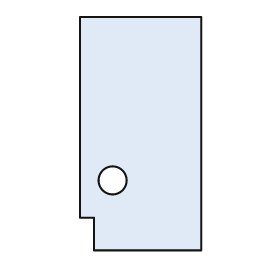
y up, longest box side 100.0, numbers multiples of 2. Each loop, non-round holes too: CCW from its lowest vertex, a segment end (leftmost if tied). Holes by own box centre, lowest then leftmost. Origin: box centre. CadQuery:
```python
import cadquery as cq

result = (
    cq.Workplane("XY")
    .moveTo(-20.0, -50.0)
    .lineTo(26.0, -50.0)
    .lineTo(26.0, 50.0)
    .lineTo(-26.0, 50.0)
    .lineTo(-26.0, -36.0)
    .lineTo(-20.0, -36.0)
    .close()
    .moveTo(-12.0, -20.0)
    .circle(6.0)
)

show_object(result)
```